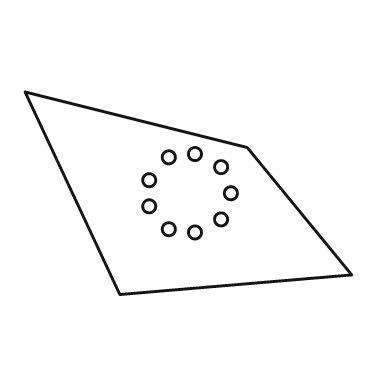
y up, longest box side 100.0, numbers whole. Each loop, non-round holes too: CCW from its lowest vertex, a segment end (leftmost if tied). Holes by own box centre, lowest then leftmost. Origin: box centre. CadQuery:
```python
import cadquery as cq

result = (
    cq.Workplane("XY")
    .moveTo(-21.0, -31.0)
    .lineTo(50.0, -25.0)
    .lineTo(18.0, 14.0)
    .lineTo(-50.0, 31.0)
    .close()
    .moveTo(2.0, -12.0)
    .circle(2.0)
    .moveTo(-6.0, -11.0)
    .circle(2.0)
    .moveTo(10.0, -8.0)
    .circle(2.0)
    .moveTo(-12.0, -4.0)
    .circle(2.0)
    .moveTo(13.0, 0.0)
    .circle(2.0)
    .moveTo(-12.0, 4.0)
    .circle(2.0)
    .moveTo(10.0, 8.0)
    .circle(2.0)
    .moveTo(-6.0, 11.0)
    .circle(2.0)
    .moveTo(2.0, 12.0)
    .circle(2.0)
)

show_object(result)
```